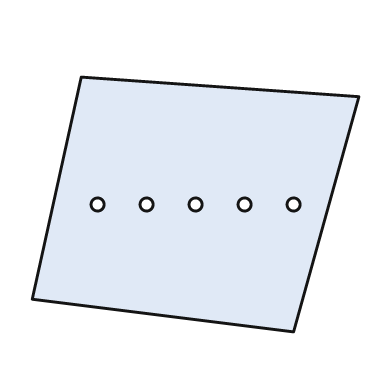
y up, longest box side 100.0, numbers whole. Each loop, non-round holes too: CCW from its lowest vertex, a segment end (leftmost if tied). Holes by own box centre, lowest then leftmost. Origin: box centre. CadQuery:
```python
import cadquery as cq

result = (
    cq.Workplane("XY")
    .moveTo(30.0, -39.0)
    .lineTo(50.0, 33.0)
    .lineTo(-35.0, 39.0)
    .lineTo(-50.0, -29.0)
    .close()
    .moveTo(-30.0, 0.0)
    .circle(2.0)
    .moveTo(-15.0, 0.0)
    .circle(2.0)
    .moveTo(0.0, 0.0)
    .circle(2.0)
    .moveTo(15.0, 0.0)
    .circle(2.0)
    .moveTo(30.0, 0.0)
    .circle(2.0)
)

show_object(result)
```